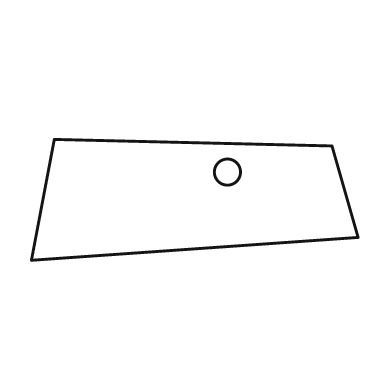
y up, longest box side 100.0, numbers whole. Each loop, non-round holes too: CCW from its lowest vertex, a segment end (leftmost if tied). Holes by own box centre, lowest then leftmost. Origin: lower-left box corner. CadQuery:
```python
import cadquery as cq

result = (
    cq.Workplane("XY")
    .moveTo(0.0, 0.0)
    .lineTo(100.0, 7.0)
    .lineTo(92.0, 35.0)
    .lineTo(7.0, 37.0)
    .close()
    .moveTo(60.0, 27.0)
    .circle(4.0)
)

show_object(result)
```